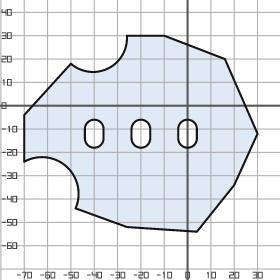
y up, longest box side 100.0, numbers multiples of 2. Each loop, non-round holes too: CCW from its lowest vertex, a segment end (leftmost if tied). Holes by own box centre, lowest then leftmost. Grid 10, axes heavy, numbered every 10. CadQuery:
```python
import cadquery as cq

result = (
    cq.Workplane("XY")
    .moveTo(4.0, -54.0)
    .lineTo(20.0, -34.0)
    .lineTo(30.0, -12.0)
    .lineTo(16.0, 20.0)
    .lineTo(-10.0, 30.0)
    .lineTo(-26.0, 30.0)
    .threePointArc((-34.0, 16.0), (-50.0, 18.0))
    .lineTo(-70.0, -4.0)
    .lineTo(-70.0, -24.0)
    .threePointArc((-52.0, -26.0), (-48.0, -44.0))
    .lineTo(-26.0, -52.0)
    .close()
    .moveTo(-44.0, -14.0)
    .threePointArc((-40.0, -18.0), (-36.0, -14.0))
    .lineTo(-36.0, -10.0)
    .threePointArc((-40.0, -6.0), (-44.0, -10.0))
    .close()
    .moveTo(-24.0, -14.0)
    .threePointArc((-20.0, -18.0), (-16.0, -14.0))
    .lineTo(-16.0, -10.0)
    .threePointArc((-20.0, -6.0), (-24.0, -10.0))
    .close()
    .moveTo(-4.0, -14.0)
    .threePointArc((0.0, -18.0), (4.0, -14.0))
    .lineTo(4.0, -10.0)
    .threePointArc((0.0, -6.0), (-4.0, -10.0))
    .close()
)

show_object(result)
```